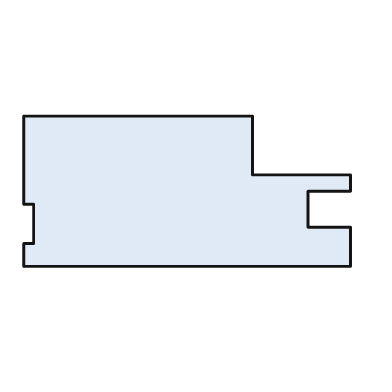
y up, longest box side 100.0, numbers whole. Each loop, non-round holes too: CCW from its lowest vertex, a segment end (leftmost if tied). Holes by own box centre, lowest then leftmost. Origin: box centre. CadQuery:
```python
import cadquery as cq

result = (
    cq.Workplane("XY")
    .moveTo(-50.0, -23.0)
    .lineTo(50.0, -23.0)
    .lineTo(50.0, -11.0)
    .lineTo(37.0, -11.0)
    .lineTo(37.0, 0.0)
    .lineTo(50.0, 0.0)
    .lineTo(50.0, 5.0)
    .lineTo(20.0, 5.0)
    .lineTo(20.0, 23.0)
    .lineTo(-50.0, 23.0)
    .lineTo(-50.0, -4.0)
    .lineTo(-47.0, -4.0)
    .lineTo(-47.0, -16.0)
    .lineTo(-50.0, -16.0)
    .close()
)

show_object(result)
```